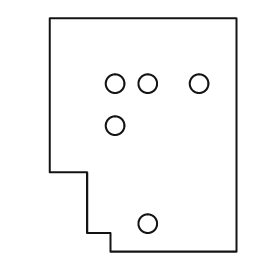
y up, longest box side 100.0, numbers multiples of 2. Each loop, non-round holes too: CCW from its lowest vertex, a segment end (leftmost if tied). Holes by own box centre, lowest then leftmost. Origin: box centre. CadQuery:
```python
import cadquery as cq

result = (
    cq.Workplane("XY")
    .moveTo(-14.0, -50.0)
    .lineTo(40.0, -50.0)
    .lineTo(40.0, 50.0)
    .lineTo(-40.0, 50.0)
    .lineTo(-40.0, -16.0)
    .lineTo(-24.0, -16.0)
    .lineTo(-24.0, -42.0)
    .lineTo(-14.0, -42.0)
    .close()
    .moveTo(2.0, -38.0)
    .circle(4.0)
    .moveTo(-12.0, 4.0)
    .circle(4.0)
    .moveTo(-12.0, 22.0)
    .circle(4.0)
    .moveTo(2.0, 22.0)
    .circle(4.0)
    .moveTo(24.0, 22.0)
    .circle(4.0)
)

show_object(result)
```